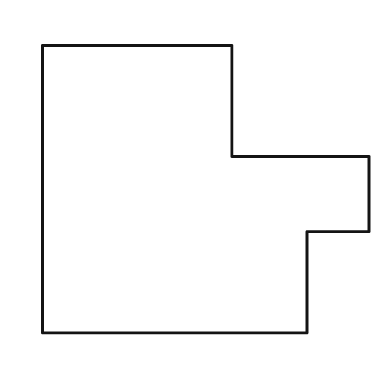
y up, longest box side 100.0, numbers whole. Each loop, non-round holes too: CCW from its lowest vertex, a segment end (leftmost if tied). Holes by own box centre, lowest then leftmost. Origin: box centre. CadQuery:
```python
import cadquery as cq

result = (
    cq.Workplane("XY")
    .moveTo(-50.0, -44.0)
    .lineTo(31.0, -44.0)
    .lineTo(31.0, -13.0)
    .lineTo(50.0, -13.0)
    .lineTo(50.0, 10.0)
    .lineTo(8.0, 10.0)
    .lineTo(8.0, 44.0)
    .lineTo(-50.0, 44.0)
    .close()
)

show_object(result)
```